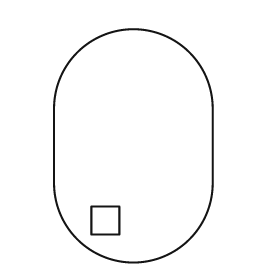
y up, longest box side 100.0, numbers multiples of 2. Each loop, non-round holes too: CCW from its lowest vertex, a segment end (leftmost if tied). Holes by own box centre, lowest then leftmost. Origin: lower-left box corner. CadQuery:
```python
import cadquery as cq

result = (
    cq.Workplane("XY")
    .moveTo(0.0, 34.0)
    .threePointArc((34.0, 0.0), (68.0, 34.0))
    .lineTo(68.0, 66.0)
    .threePointArc((34.0, 100.0), (0.0, 66.0))
    .close()
    .moveTo(16.0, 12.0)
    .lineTo(28.0, 12.0)
    .lineTo(28.0, 24.0)
    .lineTo(16.0, 24.0)
    .close()
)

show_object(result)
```